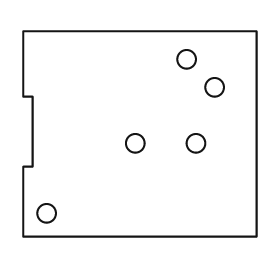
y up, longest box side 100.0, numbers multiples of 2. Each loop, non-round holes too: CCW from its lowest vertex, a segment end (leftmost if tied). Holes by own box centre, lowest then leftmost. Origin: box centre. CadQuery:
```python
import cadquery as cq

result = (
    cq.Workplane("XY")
    .moveTo(-50.0, -44.0)
    .lineTo(50.0, -44.0)
    .lineTo(50.0, 44.0)
    .lineTo(-50.0, 44.0)
    .lineTo(-50.0, 16.0)
    .lineTo(-46.0, 16.0)
    .lineTo(-46.0, -14.0)
    .lineTo(-50.0, -14.0)
    .close()
    .moveTo(-40.0, -34.0)
    .circle(4.0)
    .moveTo(-2.0, -4.0)
    .circle(4.0)
    .moveTo(24.0, -4.0)
    .circle(4.0)
    .moveTo(32.0, 20.0)
    .circle(4.0)
    .moveTo(20.0, 32.0)
    .circle(4.0)
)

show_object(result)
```